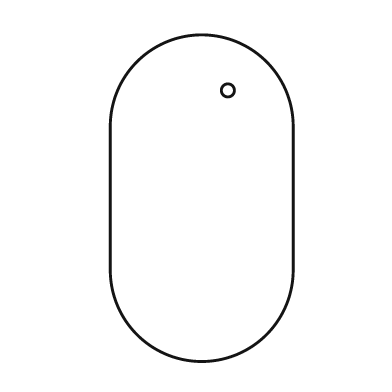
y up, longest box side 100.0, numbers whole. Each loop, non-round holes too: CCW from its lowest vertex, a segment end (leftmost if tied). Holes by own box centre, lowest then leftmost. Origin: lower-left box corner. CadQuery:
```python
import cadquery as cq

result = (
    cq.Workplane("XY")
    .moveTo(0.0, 28.0)
    .threePointArc((28.0, 0.0), (56.0, 28.0))
    .lineTo(56.0, 72.0)
    .threePointArc((28.0, 100.0), (0.0, 72.0))
    .close()
    .moveTo(36.0, 83.0)
    .circle(2.0)
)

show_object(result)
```